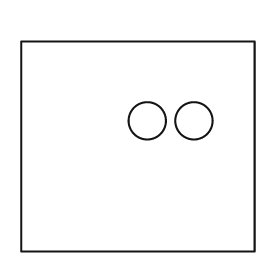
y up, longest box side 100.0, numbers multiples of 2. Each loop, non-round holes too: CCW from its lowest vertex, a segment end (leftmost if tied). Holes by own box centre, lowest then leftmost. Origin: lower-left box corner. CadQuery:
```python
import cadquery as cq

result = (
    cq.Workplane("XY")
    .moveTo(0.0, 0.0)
    .lineTo(100.0, 0.0)
    .lineTo(100.0, 90.0)
    .lineTo(0.0, 90.0)
    .close()
    .moveTo(54.0, 56.0)
    .circle(8.0)
    .moveTo(74.0, 56.0)
    .circle(8.0)
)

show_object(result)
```